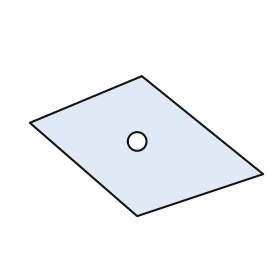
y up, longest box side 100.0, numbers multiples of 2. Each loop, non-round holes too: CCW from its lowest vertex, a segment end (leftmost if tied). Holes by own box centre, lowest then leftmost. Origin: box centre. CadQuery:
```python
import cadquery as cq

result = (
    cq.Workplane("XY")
    .moveTo(-4.0, -30.0)
    .lineTo(50.0, -12.0)
    .lineTo(-2.0, 30.0)
    .lineTo(-50.0, 10.0)
    .close()
    .moveTo(-4.0, 2.0)
    .circle(4.0)
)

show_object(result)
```